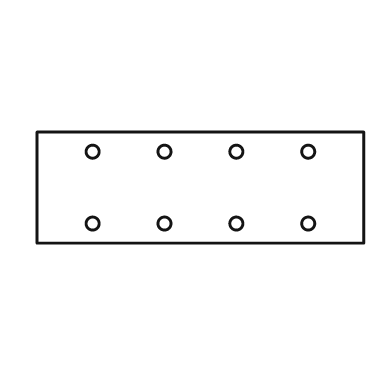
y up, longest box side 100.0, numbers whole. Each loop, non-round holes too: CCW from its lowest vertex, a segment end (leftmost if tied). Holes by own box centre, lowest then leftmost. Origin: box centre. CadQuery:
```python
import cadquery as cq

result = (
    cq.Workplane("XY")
    .moveTo(-50.0, -17.0)
    .lineTo(50.0, -17.0)
    .lineTo(50.0, 17.0)
    .lineTo(-50.0, 17.0)
    .close()
    .moveTo(-33.0, -11.0)
    .circle(2.0)
    .moveTo(-11.0, -11.0)
    .circle(2.0)
    .moveTo(11.0, -11.0)
    .circle(2.0)
    .moveTo(33.0, -11.0)
    .circle(2.0)
    .moveTo(-33.0, 11.0)
    .circle(2.0)
    .moveTo(-11.0, 11.0)
    .circle(2.0)
    .moveTo(11.0, 11.0)
    .circle(2.0)
    .moveTo(33.0, 11.0)
    .circle(2.0)
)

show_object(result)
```